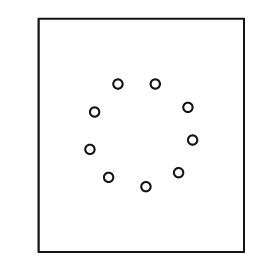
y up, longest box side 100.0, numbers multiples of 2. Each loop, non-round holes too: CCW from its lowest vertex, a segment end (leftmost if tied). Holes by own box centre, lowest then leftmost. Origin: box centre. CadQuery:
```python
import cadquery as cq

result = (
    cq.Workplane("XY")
    .moveTo(-44.0, -50.0)
    .lineTo(44.0, -50.0)
    .lineTo(44.0, 50.0)
    .lineTo(-44.0, 50.0)
    .close()
    .moveTo(2.0, -22.0)
    .circle(2.0)
    .moveTo(-14.0, -18.0)
    .circle(2.0)
    .moveTo(16.0, -16.0)
    .circle(2.0)
    .moveTo(-22.0, -6.0)
    .circle(2.0)
    .moveTo(22.0, -2.0)
    .circle(2.0)
    .moveTo(-20.0, 10.0)
    .circle(2.0)
    .moveTo(20.0, 12.0)
    .circle(2.0)
    .moveTo(-10.0, 22.0)
    .circle(2.0)
    .moveTo(6.0, 22.0)
    .circle(2.0)
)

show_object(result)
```